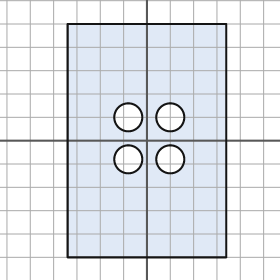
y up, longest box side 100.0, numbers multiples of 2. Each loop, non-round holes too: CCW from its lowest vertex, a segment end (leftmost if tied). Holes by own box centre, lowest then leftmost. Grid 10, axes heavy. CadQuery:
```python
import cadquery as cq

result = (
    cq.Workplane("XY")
    .moveTo(-34.0, -50.0)
    .lineTo(34.0, -50.0)
    .lineTo(34.0, 50.0)
    .lineTo(-34.0, 50.0)
    .close()
    .moveTo(-8.0, -8.0)
    .circle(6.0)
    .moveTo(10.0, -8.0)
    .circle(6.0)
    .moveTo(-8.0, 10.0)
    .circle(6.0)
    .moveTo(10.0, 10.0)
    .circle(6.0)
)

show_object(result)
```